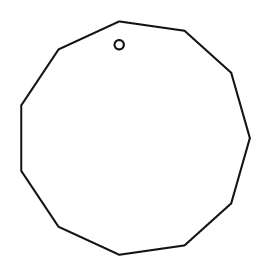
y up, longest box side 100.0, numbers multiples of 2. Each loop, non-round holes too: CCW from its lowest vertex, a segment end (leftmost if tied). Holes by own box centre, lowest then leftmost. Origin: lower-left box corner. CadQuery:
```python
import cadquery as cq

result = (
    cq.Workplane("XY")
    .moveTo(42.0, 0.0)
    .lineTo(70.0, 4.0)
    .lineTo(90.0, 22.0)
    .lineTo(98.0, 50.0)
    .lineTo(90.0, 78.0)
    .lineTo(70.0, 96.0)
    .lineTo(42.0, 100.0)
    .lineTo(16.0, 88.0)
    .lineTo(0.0, 64.0)
    .lineTo(0.0, 36.0)
    .lineTo(16.0, 12.0)
    .close()
    .moveTo(42.0, 90.0)
    .circle(2.0)
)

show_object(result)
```